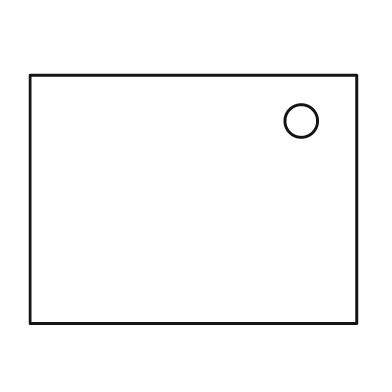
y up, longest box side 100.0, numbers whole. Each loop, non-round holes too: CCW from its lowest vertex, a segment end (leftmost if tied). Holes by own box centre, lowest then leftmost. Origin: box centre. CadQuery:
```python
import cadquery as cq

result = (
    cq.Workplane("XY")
    .moveTo(-50.0, -38.0)
    .lineTo(50.0, -38.0)
    .lineTo(50.0, 38.0)
    .lineTo(-50.0, 38.0)
    .close()
    .moveTo(33.0, 24.0)
    .circle(5.0)
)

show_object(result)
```